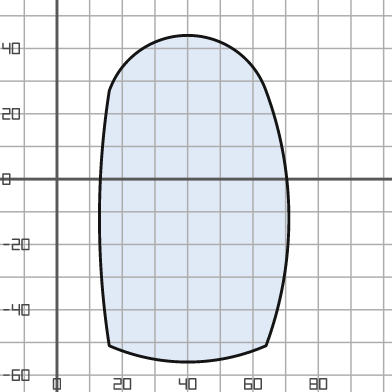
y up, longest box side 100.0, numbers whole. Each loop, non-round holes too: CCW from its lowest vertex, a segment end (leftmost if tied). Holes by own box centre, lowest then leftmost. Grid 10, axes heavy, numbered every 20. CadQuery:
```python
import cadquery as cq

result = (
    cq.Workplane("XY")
    .moveTo(16.0, -51.0)
    .threePointArc((40.0, -56.0), (64.0, -51.0))
    .threePointArc((71.0, -12.0), (64.0, 27.0))
    .threePointArc((40.0, 44.0), (16.0, 27.0))
    .threePointArc((13.0, -12.0), (16.0, -51.0))
    .close()
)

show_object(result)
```